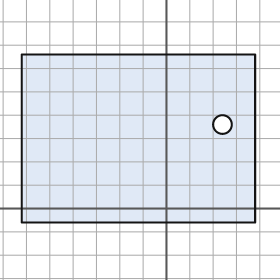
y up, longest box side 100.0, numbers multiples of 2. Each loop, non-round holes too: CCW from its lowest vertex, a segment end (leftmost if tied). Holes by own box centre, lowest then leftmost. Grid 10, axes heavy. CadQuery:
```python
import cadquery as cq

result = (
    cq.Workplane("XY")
    .moveTo(-62.0, -6.0)
    .lineTo(38.0, -6.0)
    .lineTo(38.0, 66.0)
    .lineTo(-62.0, 66.0)
    .close()
    .moveTo(24.0, 36.0)
    .circle(4.0)
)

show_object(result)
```